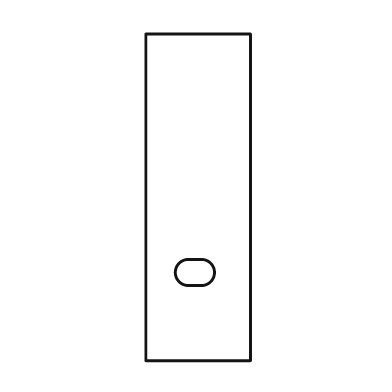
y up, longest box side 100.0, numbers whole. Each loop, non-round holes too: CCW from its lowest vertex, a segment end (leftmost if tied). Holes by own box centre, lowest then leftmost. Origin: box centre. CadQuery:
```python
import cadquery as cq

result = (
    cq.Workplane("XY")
    .moveTo(-16.0, -50.0)
    .lineTo(16.0, -50.0)
    .lineTo(16.0, 50.0)
    .lineTo(-16.0, 50.0)
    .close()
    .moveTo(-3.0, -27.0)
    .lineTo(1.0, -27.0)
    .threePointArc((5.0, -23.0), (1.0, -19.0))
    .lineTo(-3.0, -19.0)
    .threePointArc((-7.0, -23.0), (-3.0, -27.0))
    .close()
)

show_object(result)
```